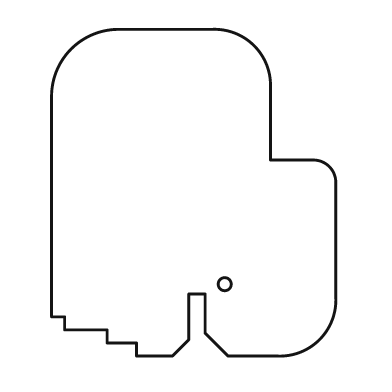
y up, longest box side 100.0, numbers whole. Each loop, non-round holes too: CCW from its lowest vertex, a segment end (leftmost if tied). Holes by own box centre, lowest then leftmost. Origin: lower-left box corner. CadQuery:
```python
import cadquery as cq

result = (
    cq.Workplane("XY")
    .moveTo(26.0, 0.0)
    .lineTo(37.0, 0.0)
    .lineTo(42.0, 5.0)
    .lineTo(42.0, 19.0)
    .lineTo(47.0, 19.0)
    .lineTo(47.0, 7.0)
    .lineTo(54.0, 0.0)
    .lineTo(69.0, 0.0)
    .threePointArc((82.0, 5.0), (87.0, 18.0))
    .lineTo(87.0, 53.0)
    .threePointArc((85.0, 58.0), (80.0, 60.0))
    .lineTo(67.0, 60.0)
    .lineTo(67.0, 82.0)
    .threePointArc((62.0, 95.0), (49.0, 100.0))
    .lineTo(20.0, 100.0)
    .threePointArc((6.0, 94.0), (0.0, 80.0))
    .lineTo(0.0, 12.0)
    .lineTo(4.0, 12.0)
    .lineTo(4.0, 8.0)
    .lineTo(17.0, 8.0)
    .lineTo(17.0, 4.0)
    .lineTo(26.0, 4.0)
    .close()
    .moveTo(53.0, 22.0)
    .circle(2.0)
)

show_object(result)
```